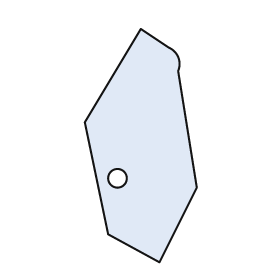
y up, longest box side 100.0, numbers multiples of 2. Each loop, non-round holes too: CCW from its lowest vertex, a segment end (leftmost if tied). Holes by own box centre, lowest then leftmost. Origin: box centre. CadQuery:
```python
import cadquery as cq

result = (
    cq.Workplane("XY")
    .moveTo(8.0, -50.0)
    .lineTo(24.0, -18.0)
    .lineTo(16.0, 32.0)
    .threePointArc((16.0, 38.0), (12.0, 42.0))
    .lineTo(0.0, 50.0)
    .lineTo(-24.0, 10.0)
    .lineTo(-14.0, -38.0)
    .close()
    .moveTo(-10.0, -14.0)
    .circle(4.0)
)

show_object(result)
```